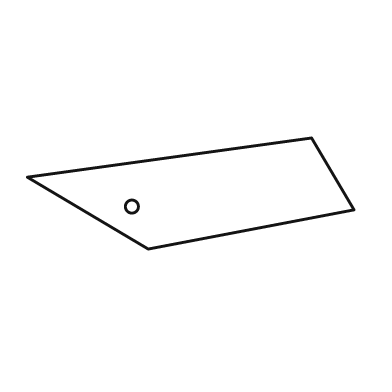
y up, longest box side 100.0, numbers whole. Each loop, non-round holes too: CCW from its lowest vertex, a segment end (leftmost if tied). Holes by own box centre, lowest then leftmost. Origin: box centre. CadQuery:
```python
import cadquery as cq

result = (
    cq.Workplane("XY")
    .moveTo(-13.0, -17.0)
    .lineTo(50.0, -5.0)
    .lineTo(37.0, 17.0)
    .lineTo(-50.0, 5.0)
    .close()
    .moveTo(-18.0, -4.0)
    .circle(2.0)
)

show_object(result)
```